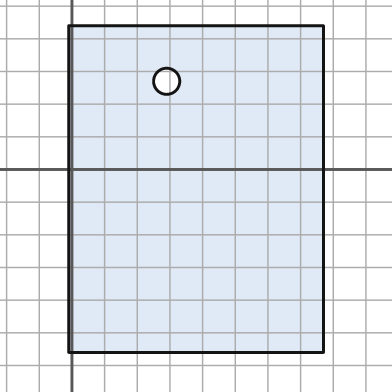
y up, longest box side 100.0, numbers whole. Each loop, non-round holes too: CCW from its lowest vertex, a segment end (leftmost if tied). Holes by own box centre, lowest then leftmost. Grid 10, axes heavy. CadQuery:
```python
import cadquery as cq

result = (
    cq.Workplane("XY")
    .moveTo(-1.0, -56.0)
    .lineTo(77.0, -56.0)
    .lineTo(77.0, 44.0)
    .lineTo(-1.0, 44.0)
    .close()
    .moveTo(29.0, 27.0)
    .circle(4.0)
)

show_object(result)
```